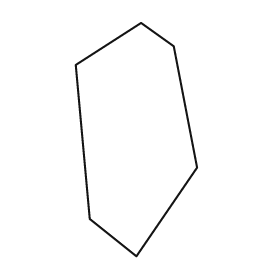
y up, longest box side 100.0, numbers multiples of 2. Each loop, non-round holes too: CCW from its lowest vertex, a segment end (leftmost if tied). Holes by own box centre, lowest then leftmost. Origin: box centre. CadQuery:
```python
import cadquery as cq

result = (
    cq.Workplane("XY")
    .moveTo(0.0, -50.0)
    .lineTo(26.0, -12.0)
    .lineTo(16.0, 40.0)
    .lineTo(2.0, 50.0)
    .lineTo(-26.0, 32.0)
    .lineTo(-20.0, -34.0)
    .close()
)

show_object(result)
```